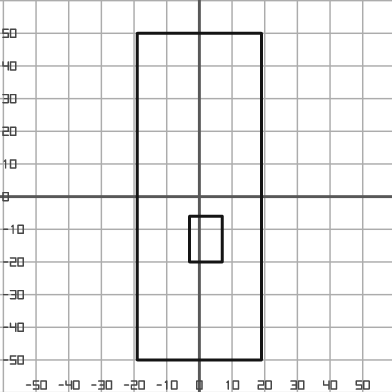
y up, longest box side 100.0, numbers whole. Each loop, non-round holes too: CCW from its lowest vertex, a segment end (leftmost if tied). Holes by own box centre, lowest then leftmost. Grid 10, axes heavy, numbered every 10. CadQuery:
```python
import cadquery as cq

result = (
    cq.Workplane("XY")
    .moveTo(-19.0, -50.0)
    .lineTo(19.0, -50.0)
    .lineTo(19.0, 50.0)
    .lineTo(-19.0, 50.0)
    .close()
    .moveTo(-3.0, -20.0)
    .lineTo(7.0, -20.0)
    .lineTo(7.0, -6.0)
    .lineTo(-3.0, -6.0)
    .close()
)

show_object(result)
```